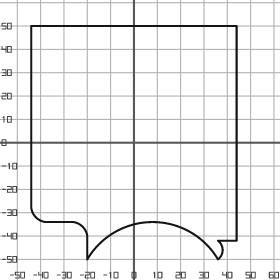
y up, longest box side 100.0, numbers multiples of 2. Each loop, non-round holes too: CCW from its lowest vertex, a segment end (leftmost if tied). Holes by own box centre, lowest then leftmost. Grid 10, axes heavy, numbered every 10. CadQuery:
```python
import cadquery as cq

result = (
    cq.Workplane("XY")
    .moveTo(-20.0, -50.0)
    .threePointArc((8.0, -34.0), (36.0, -50.0))
    .threePointArc((38.0, -46.0), (36.0, -42.0))
    .lineTo(44.0, -42.0)
    .lineTo(44.0, 50.0)
    .lineTo(-44.0, 50.0)
    .lineTo(-44.0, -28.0)
    .threePointArc((-42.0, -32.0), (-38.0, -34.0))
    .lineTo(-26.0, -34.0)
    .threePointArc((-22.0, -36.0), (-20.0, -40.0))
    .close()
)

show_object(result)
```